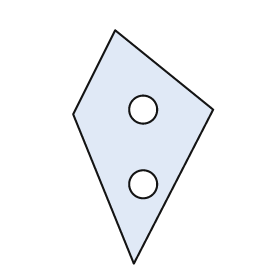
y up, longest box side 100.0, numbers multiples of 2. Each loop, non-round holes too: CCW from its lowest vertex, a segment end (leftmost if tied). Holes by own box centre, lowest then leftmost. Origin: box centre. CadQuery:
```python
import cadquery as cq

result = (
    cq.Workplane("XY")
    .moveTo(-4.0, -50.0)
    .lineTo(30.0, 16.0)
    .lineTo(-12.0, 50.0)
    .lineTo(-30.0, 14.0)
    .close()
    .moveTo(0.0, -16.0)
    .circle(6.0)
    .moveTo(0.0, 16.0)
    .circle(6.0)
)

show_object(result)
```